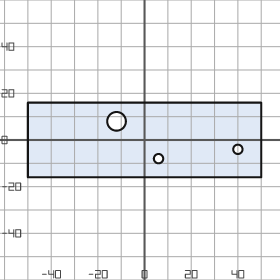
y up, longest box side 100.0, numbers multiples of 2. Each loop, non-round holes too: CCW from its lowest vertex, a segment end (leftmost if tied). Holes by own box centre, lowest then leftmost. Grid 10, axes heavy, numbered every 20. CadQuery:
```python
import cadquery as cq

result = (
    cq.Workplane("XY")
    .moveTo(-50.0, -16.0)
    .lineTo(50.0, -16.0)
    .lineTo(50.0, 16.0)
    .lineTo(-50.0, 16.0)
    .close()
    .moveTo(6.0, -8.0)
    .circle(2.0)
    .moveTo(40.0, -4.0)
    .circle(2.0)
    .moveTo(-12.0, 8.0)
    .circle(4.0)
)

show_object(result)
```